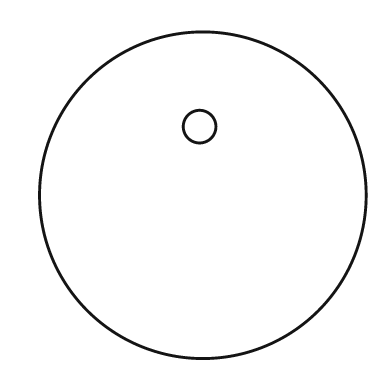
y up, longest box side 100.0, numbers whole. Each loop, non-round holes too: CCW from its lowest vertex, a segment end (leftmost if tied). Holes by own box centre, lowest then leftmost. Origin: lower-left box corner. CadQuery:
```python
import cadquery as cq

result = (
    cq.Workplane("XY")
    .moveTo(50.0, 50.0)
    .circle(50.0)
    .moveTo(49.0, 71.0)
    .circle(5.0)
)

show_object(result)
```